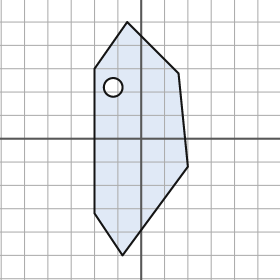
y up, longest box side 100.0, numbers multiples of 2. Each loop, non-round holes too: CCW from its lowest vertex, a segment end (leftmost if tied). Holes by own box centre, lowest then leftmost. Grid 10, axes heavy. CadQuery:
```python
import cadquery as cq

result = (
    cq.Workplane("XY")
    .moveTo(-8.0, -50.0)
    .lineTo(20.0, -12.0)
    .lineTo(16.0, 28.0)
    .lineTo(-6.0, 50.0)
    .lineTo(-20.0, 30.0)
    .lineTo(-20.0, -32.0)
    .close()
    .moveTo(-12.0, 22.0)
    .circle(4.0)
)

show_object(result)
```